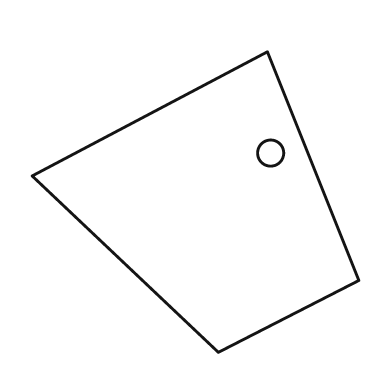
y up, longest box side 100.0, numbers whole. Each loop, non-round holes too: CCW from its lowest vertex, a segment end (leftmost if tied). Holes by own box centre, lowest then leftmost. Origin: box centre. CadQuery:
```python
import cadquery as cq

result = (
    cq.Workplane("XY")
    .moveTo(7.0, -46.0)
    .lineTo(50.0, -24.0)
    .lineTo(22.0, 46.0)
    .lineTo(-50.0, 8.0)
    .close()
    .moveTo(23.0, 15.0)
    .circle(4.0)
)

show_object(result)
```